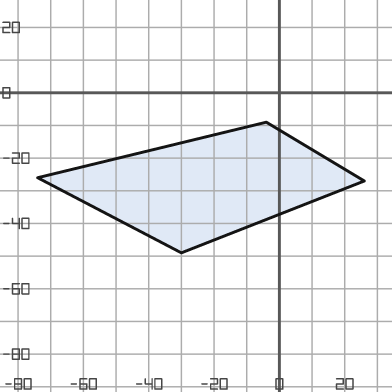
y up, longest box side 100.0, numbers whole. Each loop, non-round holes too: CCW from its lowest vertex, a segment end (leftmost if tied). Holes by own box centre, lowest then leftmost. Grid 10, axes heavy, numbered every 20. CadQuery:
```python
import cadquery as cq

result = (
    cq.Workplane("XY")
    .moveTo(-30.0, -49.0)
    .lineTo(26.0, -27.0)
    .lineTo(-4.0, -9.0)
    .lineTo(-74.0, -26.0)
    .close()
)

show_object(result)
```